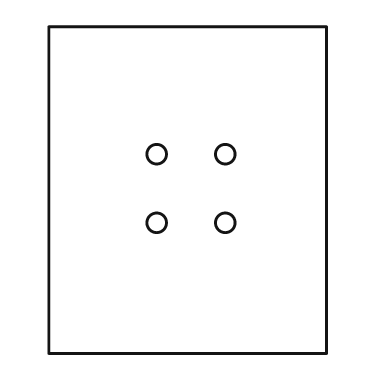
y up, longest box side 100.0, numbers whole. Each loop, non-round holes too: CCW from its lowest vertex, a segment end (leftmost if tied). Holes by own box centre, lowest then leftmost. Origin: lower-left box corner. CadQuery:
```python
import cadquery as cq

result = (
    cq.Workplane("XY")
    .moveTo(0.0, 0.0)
    .lineTo(85.0, 0.0)
    .lineTo(85.0, 100.0)
    .lineTo(0.0, 100.0)
    .close()
    .moveTo(33.0, 40.0)
    .circle(3.0)
    .moveTo(54.0, 40.0)
    .circle(3.0)
    .moveTo(33.0, 61.0)
    .circle(3.0)
    .moveTo(54.0, 61.0)
    .circle(3.0)
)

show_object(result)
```